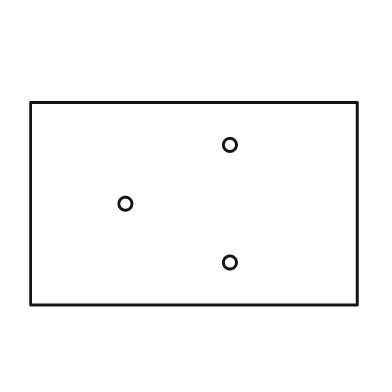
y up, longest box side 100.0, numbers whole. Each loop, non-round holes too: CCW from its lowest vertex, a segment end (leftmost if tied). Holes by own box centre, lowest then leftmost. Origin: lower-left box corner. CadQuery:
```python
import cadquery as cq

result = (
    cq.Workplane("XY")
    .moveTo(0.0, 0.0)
    .lineTo(100.0, 0.0)
    .lineTo(100.0, 62.0)
    .lineTo(0.0, 62.0)
    .close()
    .moveTo(61.0, 13.0)
    .circle(2.0)
    .moveTo(29.0, 31.0)
    .circle(2.0)
    .moveTo(61.0, 49.0)
    .circle(2.0)
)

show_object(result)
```